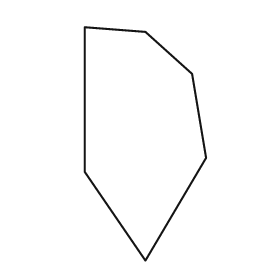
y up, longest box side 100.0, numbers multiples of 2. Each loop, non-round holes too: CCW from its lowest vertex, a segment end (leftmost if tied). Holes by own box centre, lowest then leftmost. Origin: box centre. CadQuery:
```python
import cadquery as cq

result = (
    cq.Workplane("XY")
    .moveTo(0.0, -50.0)
    .lineTo(26.0, -6.0)
    .lineTo(20.0, 30.0)
    .lineTo(0.0, 48.0)
    .lineTo(-26.0, 50.0)
    .lineTo(-26.0, -12.0)
    .close()
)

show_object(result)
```